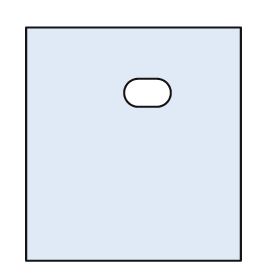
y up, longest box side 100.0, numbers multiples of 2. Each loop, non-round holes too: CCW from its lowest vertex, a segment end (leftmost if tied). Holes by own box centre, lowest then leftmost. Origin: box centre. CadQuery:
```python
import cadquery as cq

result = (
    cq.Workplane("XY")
    .moveTo(-46.0, -50.0)
    .lineTo(46.0, -50.0)
    .lineTo(46.0, 50.0)
    .lineTo(-46.0, 50.0)
    .close()
    .moveTo(2.0, 16.0)
    .lineTo(10.0, 16.0)
    .threePointArc((16.0, 22.0), (10.0, 28.0))
    .lineTo(2.0, 28.0)
    .threePointArc((-4.0, 22.0), (2.0, 16.0))
    .close()
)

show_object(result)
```